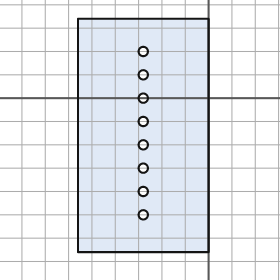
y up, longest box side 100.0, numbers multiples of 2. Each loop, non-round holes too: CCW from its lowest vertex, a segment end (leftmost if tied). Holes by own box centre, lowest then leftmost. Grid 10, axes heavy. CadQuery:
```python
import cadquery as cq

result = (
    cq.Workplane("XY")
    .moveTo(-56.0, -66.0)
    .lineTo(0.0, -66.0)
    .lineTo(0.0, 34.0)
    .lineTo(-56.0, 34.0)
    .close()
    .moveTo(-28.0, -50.0)
    .circle(2.0)
    .moveTo(-28.0, -40.0)
    .circle(2.0)
    .moveTo(-28.0, -30.0)
    .circle(2.0)
    .moveTo(-28.0, -20.0)
    .circle(2.0)
    .moveTo(-28.0, -10.0)
    .circle(2.0)
    .moveTo(-28.0, 0.0)
    .circle(2.0)
    .moveTo(-28.0, 10.0)
    .circle(2.0)
    .moveTo(-28.0, 20.0)
    .circle(2.0)
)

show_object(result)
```